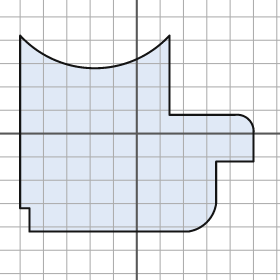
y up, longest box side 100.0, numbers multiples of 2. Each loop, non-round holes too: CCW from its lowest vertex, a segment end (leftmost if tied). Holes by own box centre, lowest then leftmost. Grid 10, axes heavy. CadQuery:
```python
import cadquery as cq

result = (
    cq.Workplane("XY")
    .moveTo(-46.0, -42.0)
    .lineTo(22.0, -42.0)
    .threePointArc((30.0, -38.0), (34.0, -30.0))
    .lineTo(34.0, -12.0)
    .lineTo(50.0, -12.0)
    .lineTo(50.0, 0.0)
    .threePointArc((48.0, 6.0), (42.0, 8.0))
    .lineTo(14.0, 8.0)
    .lineTo(14.0, 42.0)
    .threePointArc((-18.0, 28.0), (-50.0, 42.0))
    .lineTo(-50.0, -32.0)
    .lineTo(-46.0, -32.0)
    .close()
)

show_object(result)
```